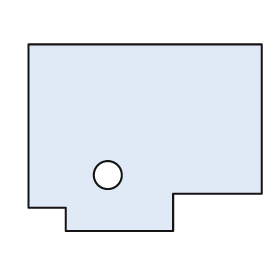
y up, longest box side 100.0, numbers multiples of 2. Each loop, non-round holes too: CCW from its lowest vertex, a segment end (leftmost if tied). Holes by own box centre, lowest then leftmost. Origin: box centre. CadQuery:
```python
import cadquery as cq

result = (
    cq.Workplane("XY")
    .moveTo(-34.0, -40.0)
    .lineTo(12.0, -40.0)
    .lineTo(12.0, -24.0)
    .lineTo(50.0, -24.0)
    .lineTo(50.0, 40.0)
    .lineTo(-50.0, 40.0)
    .lineTo(-50.0, -30.0)
    .lineTo(-34.0, -30.0)
    .close()
    .moveTo(-16.0, -16.0)
    .circle(6.0)
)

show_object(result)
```